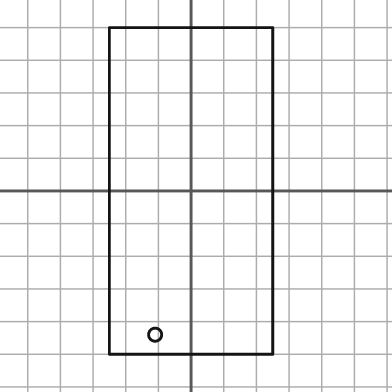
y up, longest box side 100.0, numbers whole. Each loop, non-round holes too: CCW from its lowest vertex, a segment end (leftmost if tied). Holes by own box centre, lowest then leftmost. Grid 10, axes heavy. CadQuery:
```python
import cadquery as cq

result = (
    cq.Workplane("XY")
    .moveTo(-25.0, -50.0)
    .lineTo(25.0, -50.0)
    .lineTo(25.0, 50.0)
    .lineTo(-25.0, 50.0)
    .close()
    .moveTo(-11.0, -44.0)
    .circle(2.0)
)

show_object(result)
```